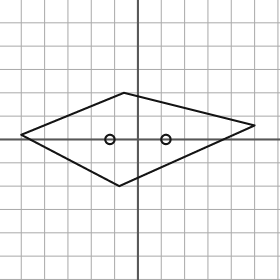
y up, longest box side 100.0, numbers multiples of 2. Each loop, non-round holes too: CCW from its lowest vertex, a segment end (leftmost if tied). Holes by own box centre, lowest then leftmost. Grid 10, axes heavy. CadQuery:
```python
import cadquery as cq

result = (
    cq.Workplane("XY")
    .moveTo(-8.0, -20.0)
    .lineTo(50.0, 6.0)
    .lineTo(-6.0, 20.0)
    .lineTo(-50.0, 2.0)
    .close()
    .moveTo(-12.0, 0.0)
    .circle(2.0)
    .moveTo(12.0, 0.0)
    .circle(2.0)
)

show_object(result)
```